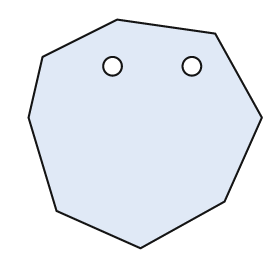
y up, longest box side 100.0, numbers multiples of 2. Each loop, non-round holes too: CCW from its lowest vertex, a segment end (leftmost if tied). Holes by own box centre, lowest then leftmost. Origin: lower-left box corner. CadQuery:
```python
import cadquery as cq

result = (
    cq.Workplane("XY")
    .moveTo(48.0, 0.0)
    .lineTo(84.0, 20.0)
    .lineTo(100.0, 56.0)
    .lineTo(80.0, 92.0)
    .lineTo(38.0, 98.0)
    .lineTo(6.0, 82.0)
    .lineTo(0.0, 56.0)
    .lineTo(12.0, 16.0)
    .close()
    .moveTo(36.0, 78.0)
    .circle(4.0)
    .moveTo(70.0, 78.0)
    .circle(4.0)
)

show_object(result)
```